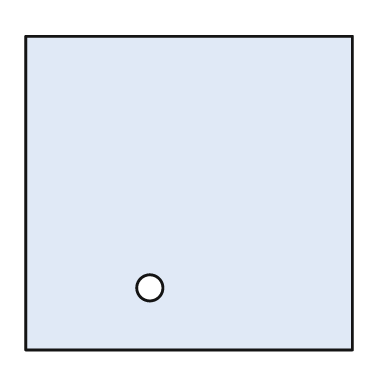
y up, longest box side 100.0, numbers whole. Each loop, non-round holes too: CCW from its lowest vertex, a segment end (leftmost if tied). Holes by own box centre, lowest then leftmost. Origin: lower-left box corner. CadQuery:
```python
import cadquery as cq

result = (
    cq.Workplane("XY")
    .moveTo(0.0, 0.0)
    .lineTo(100.0, 0.0)
    .lineTo(100.0, 96.0)
    .lineTo(0.0, 96.0)
    .close()
    .moveTo(38.0, 19.0)
    .circle(4.0)
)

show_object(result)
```